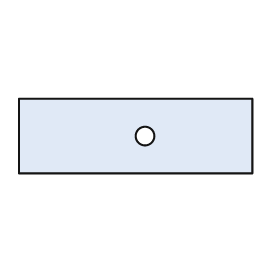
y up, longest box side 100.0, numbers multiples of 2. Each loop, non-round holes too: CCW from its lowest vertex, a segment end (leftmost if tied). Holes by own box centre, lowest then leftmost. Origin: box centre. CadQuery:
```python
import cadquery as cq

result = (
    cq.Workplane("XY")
    .moveTo(-50.0, -16.0)
    .lineTo(50.0, -16.0)
    .lineTo(50.0, 16.0)
    .lineTo(-50.0, 16.0)
    .close()
    .moveTo(4.0, 0.0)
    .circle(4.0)
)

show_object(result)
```